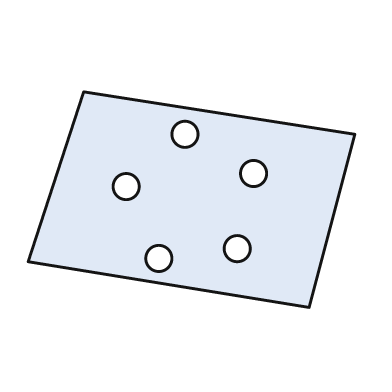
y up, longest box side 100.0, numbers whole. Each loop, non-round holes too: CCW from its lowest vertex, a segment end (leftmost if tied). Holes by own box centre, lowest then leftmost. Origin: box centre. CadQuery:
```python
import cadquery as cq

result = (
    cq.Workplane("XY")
    .moveTo(36.0, -33.0)
    .lineTo(50.0, 20.0)
    .lineTo(-33.0, 33.0)
    .lineTo(-50.0, -19.0)
    .close()
    .moveTo(-10.0, -18.0)
    .circle(4.0)
    .moveTo(14.0, -15.0)
    .circle(4.0)
    .moveTo(-20.0, 4.0)
    .circle(4.0)
    .moveTo(19.0, 8.0)
    .circle(4.0)
    .moveTo(-2.0, 20.0)
    .circle(4.0)
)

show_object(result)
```